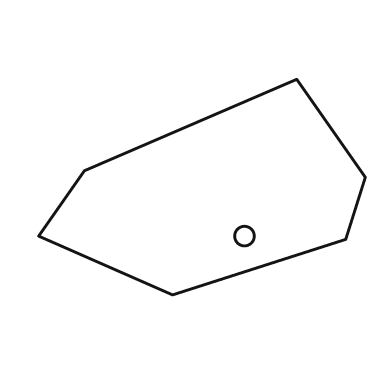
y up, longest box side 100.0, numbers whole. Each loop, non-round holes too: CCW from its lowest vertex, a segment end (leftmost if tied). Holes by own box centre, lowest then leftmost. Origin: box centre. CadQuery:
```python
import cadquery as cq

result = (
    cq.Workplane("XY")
    .moveTo(-9.0, -33.0)
    .lineTo(44.0, -16.0)
    .lineTo(50.0, 3.0)
    .lineTo(29.0, 33.0)
    .lineTo(-36.0, 5.0)
    .lineTo(-50.0, -15.0)
    .close()
    .moveTo(13.0, -15.0)
    .circle(3.0)
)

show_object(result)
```